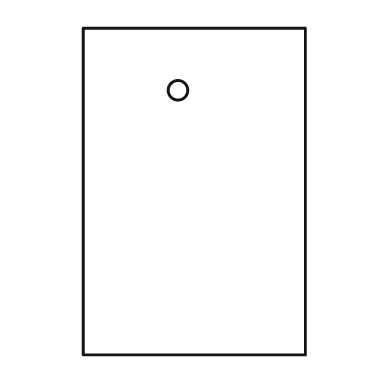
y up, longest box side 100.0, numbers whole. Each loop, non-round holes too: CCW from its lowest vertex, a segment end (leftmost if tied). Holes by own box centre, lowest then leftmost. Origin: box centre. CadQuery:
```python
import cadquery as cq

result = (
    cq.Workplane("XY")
    .moveTo(-34.0, -50.0)
    .lineTo(34.0, -50.0)
    .lineTo(34.0, 50.0)
    .lineTo(-34.0, 50.0)
    .close()
    .moveTo(-5.0, 31.0)
    .circle(3.0)
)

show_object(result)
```